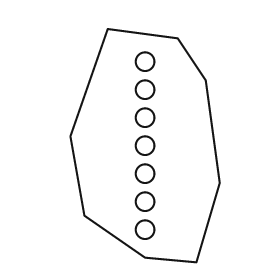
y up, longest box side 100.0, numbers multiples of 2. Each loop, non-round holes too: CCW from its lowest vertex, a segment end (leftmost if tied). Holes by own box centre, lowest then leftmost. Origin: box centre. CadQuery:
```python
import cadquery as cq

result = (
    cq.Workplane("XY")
    .moveTo(22.0, -50.0)
    .lineTo(32.0, -16.0)
    .lineTo(26.0, 28.0)
    .lineTo(14.0, 46.0)
    .lineTo(-16.0, 50.0)
    .lineTo(-32.0, 4.0)
    .lineTo(-26.0, -30.0)
    .lineTo(0.0, -48.0)
    .close()
    .moveTo(0.0, -36.0)
    .circle(4.0)
    .moveTo(0.0, -24.0)
    .circle(4.0)
    .moveTo(0.0, -12.0)
    .circle(4.0)
    .moveTo(0.0, 0.0)
    .circle(4.0)
    .moveTo(0.0, 12.0)
    .circle(4.0)
    .moveTo(0.0, 24.0)
    .circle(4.0)
    .moveTo(0.0, 36.0)
    .circle(4.0)
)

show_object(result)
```